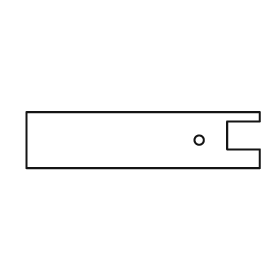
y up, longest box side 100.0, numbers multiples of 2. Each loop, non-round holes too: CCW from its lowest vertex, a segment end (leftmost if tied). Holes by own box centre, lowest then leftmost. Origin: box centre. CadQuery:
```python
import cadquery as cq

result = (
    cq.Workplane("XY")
    .moveTo(-50.0, -12.0)
    .lineTo(50.0, -12.0)
    .lineTo(50.0, -4.0)
    .lineTo(36.0, -4.0)
    .lineTo(36.0, 8.0)
    .lineTo(50.0, 8.0)
    .lineTo(50.0, 12.0)
    .lineTo(-50.0, 12.0)
    .close()
    .moveTo(24.0, 0.0)
    .circle(2.0)
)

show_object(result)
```